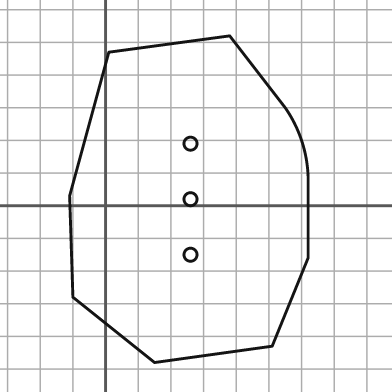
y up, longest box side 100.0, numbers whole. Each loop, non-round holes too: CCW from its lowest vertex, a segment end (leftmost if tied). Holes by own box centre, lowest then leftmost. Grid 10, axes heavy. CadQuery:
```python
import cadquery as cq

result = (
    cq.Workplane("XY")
    .moveTo(15.0, -48.0)
    .lineTo(51.0, -43.0)
    .lineTo(62.0, -16.0)
    .lineTo(62.0, 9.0)
    .threePointArc((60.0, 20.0), (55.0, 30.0))
    .lineTo(38.0, 52.0)
    .lineTo(1.0, 47.0)
    .lineTo(-11.0, 3.0)
    .lineTo(-10.0, -28.0)
    .close()
    .moveTo(26.0, -15.0)
    .circle(2.0)
    .moveTo(26.0, 2.0)
    .circle(2.0)
    .moveTo(26.0, 19.0)
    .circle(2.0)
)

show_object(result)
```